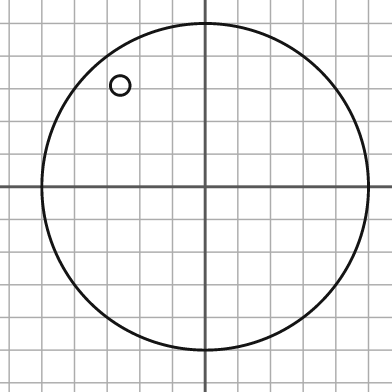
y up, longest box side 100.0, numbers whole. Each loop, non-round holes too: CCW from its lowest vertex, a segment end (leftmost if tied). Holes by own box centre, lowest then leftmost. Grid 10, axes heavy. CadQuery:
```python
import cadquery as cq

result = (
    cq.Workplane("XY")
    .moveTo(0.0, 0.0)
    .circle(50.0)
    .moveTo(-26.0, 31.0)
    .circle(3.0)
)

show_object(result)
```